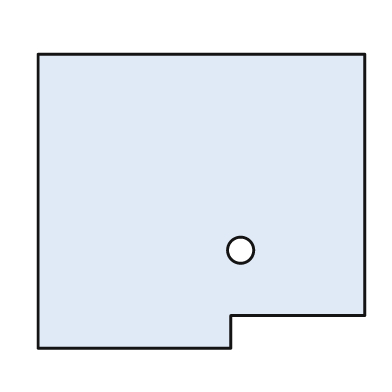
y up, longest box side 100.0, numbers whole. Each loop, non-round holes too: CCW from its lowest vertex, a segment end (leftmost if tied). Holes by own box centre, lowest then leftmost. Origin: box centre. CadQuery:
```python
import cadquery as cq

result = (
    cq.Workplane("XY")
    .moveTo(-50.0, -45.0)
    .lineTo(9.0, -45.0)
    .lineTo(9.0, -35.0)
    .lineTo(50.0, -35.0)
    .lineTo(50.0, 45.0)
    .lineTo(-50.0, 45.0)
    .close()
    .moveTo(12.0, -15.0)
    .circle(4.0)
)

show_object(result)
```